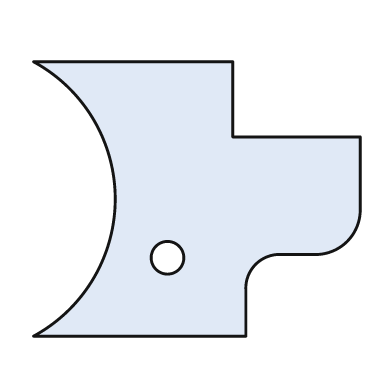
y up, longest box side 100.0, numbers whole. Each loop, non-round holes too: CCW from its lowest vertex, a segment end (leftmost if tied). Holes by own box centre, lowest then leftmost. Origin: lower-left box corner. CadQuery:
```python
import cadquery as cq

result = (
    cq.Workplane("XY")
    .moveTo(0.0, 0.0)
    .lineTo(65.0, 0.0)
    .lineTo(65.0, 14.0)
    .threePointArc((68.0, 22.0), (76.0, 25.0))
    .lineTo(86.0, 25.0)
    .threePointArc((96.0, 29.0), (100.0, 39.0))
    .lineTo(100.0, 61.0)
    .lineTo(61.0, 61.0)
    .lineTo(61.0, 84.0)
    .lineTo(0.0, 84.0)
    .threePointArc((25.0, 42.0), (0.0, 0.0))
    .close()
    .moveTo(41.0, 24.0)
    .circle(5.0)
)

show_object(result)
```